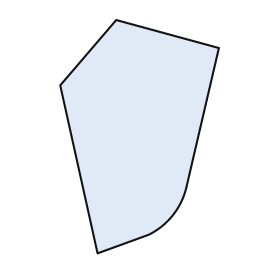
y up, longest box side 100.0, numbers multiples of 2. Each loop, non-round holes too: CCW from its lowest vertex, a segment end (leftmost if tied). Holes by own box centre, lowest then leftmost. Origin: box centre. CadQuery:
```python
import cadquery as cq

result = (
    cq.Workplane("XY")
    .moveTo(-18.0, -50.0)
    .lineTo(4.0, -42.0)
    .threePointArc((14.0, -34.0), (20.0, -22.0))
    .lineTo(34.0, 38.0)
    .lineTo(-10.0, 50.0)
    .lineTo(-34.0, 22.0)
    .close()
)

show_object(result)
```